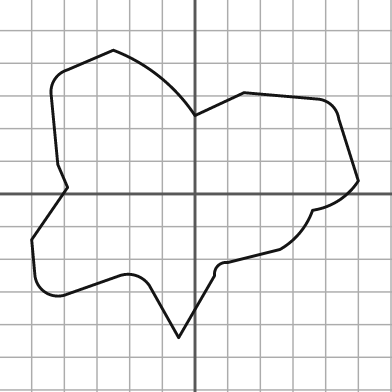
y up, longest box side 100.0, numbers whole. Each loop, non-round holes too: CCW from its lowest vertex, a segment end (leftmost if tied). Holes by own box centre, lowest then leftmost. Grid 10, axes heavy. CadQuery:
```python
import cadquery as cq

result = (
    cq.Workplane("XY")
    .moveTo(-5.0, -44.0)
    .lineTo(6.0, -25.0)
    .threePointArc((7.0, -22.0), (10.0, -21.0))
    .lineTo(26.0, -17.0)
    .threePointArc((32.0, -12.0), (36.0, -5.0))
    .threePointArc((44.0, -2.0), (50.0, 4.0))
    .lineTo(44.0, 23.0)
    .threePointArc((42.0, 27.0), (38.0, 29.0))
    .lineTo(15.0, 31.0)
    .lineTo(0.0, 24.0)
    .threePointArc((-11.0, 36.0), (-25.0, 44.0))
    .lineTo(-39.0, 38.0)
    .threePointArc((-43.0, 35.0), (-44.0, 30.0))
    .lineTo(-42.0, 9.0)
    .lineTo(-39.0, 2.0)
    .lineTo(-50.0, -14.0)
    .lineTo(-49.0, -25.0)
    .threePointArc((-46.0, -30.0), (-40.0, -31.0))
    .lineTo(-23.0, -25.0)
    .threePointArc((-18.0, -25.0), (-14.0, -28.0))
    .close()
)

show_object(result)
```